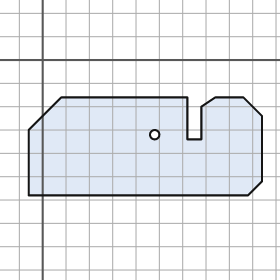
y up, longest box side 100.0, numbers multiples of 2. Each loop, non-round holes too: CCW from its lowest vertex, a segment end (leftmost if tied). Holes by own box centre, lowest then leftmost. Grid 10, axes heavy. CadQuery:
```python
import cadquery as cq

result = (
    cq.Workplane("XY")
    .moveTo(-6.0, -58.0)
    .lineTo(88.0, -58.0)
    .lineTo(94.0, -52.0)
    .lineTo(94.0, -24.0)
    .lineTo(86.0, -16.0)
    .lineTo(74.0, -16.0)
    .lineTo(68.0, -20.0)
    .lineTo(68.0, -34.0)
    .lineTo(62.0, -34.0)
    .lineTo(62.0, -16.0)
    .lineTo(8.0, -16.0)
    .lineTo(-6.0, -30.0)
    .close()
    .moveTo(48.0, -32.0)
    .circle(2.0)
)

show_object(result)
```